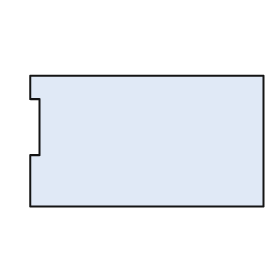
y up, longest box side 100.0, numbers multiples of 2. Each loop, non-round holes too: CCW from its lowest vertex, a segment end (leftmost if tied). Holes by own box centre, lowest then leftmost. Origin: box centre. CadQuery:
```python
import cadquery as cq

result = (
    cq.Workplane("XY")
    .moveTo(-50.0, -28.0)
    .lineTo(50.0, -28.0)
    .lineTo(50.0, 28.0)
    .lineTo(-50.0, 28.0)
    .lineTo(-50.0, 18.0)
    .lineTo(-46.0, 18.0)
    .lineTo(-46.0, -6.0)
    .lineTo(-50.0, -6.0)
    .close()
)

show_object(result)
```